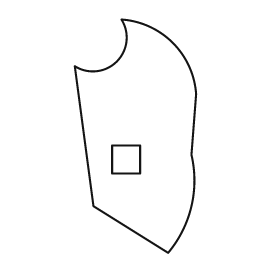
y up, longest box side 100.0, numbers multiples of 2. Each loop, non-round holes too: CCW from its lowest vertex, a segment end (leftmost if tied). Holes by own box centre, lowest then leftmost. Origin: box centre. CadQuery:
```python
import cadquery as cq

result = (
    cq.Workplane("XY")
    .moveTo(14.0, -50.0)
    .threePointArc((24.0, -30.0), (24.0, -8.0))
    .lineTo(26.0, 18.0)
    .threePointArc((16.0, 40.0), (-6.0, 50.0))
    .threePointArc((-8.0, 32.0), (-26.0, 30.0))
    .lineTo(-18.0, -30.0)
    .close()
    .moveTo(-10.0, -16.0)
    .lineTo(2.0, -16.0)
    .lineTo(2.0, -4.0)
    .lineTo(-10.0, -4.0)
    .close()
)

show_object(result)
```